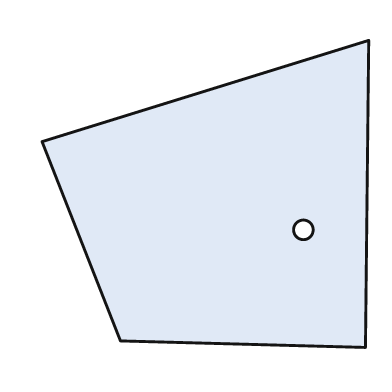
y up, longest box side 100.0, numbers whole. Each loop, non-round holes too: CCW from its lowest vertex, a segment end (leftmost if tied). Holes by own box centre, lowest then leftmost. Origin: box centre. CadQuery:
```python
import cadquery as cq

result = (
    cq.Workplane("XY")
    .moveTo(49.0, -47.0)
    .lineTo(50.0, 47.0)
    .lineTo(-50.0, 16.0)
    .lineTo(-26.0, -45.0)
    .close()
    .moveTo(30.0, -11.0)
    .circle(3.0)
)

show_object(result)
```